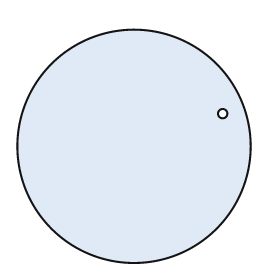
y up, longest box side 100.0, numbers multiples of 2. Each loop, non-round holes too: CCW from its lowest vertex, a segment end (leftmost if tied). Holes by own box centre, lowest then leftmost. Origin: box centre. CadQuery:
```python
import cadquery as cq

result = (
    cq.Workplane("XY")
    .moveTo(0.0, 0.0)
    .circle(50.0)
    .moveTo(38.0, 14.0)
    .circle(2.0)
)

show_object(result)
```